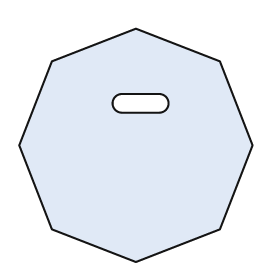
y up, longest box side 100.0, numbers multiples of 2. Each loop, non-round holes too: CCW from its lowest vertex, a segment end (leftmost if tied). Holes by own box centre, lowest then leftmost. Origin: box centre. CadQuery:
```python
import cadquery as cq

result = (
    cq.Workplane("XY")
    .moveTo(0.0, -50.0)
    .lineTo(36.0, -36.0)
    .lineTo(50.0, 0.0)
    .lineTo(36.0, 36.0)
    .lineTo(0.0, 50.0)
    .lineTo(-36.0, 36.0)
    .lineTo(-50.0, 0.0)
    .lineTo(-36.0, -36.0)
    .close()
    .moveTo(-6.0, 14.0)
    .lineTo(10.0, 14.0)
    .threePointArc((14.0, 18.0), (10.0, 22.0))
    .lineTo(-6.0, 22.0)
    .threePointArc((-10.0, 18.0), (-6.0, 14.0))
    .close()
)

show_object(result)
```